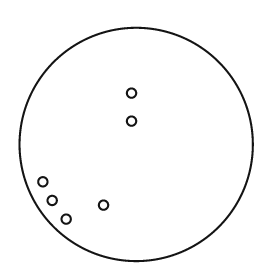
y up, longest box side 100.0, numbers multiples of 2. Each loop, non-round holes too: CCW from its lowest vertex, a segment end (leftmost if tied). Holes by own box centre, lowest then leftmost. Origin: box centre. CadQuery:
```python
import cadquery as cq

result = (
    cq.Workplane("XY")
    .moveTo(0.0, 0.0)
    .circle(50.0)
    .moveTo(-30.0, -32.0)
    .circle(2.0)
    .moveTo(-14.0, -26.0)
    .circle(2.0)
    .moveTo(-36.0, -24.0)
    .circle(2.0)
    .moveTo(-40.0, -16.0)
    .circle(2.0)
    .moveTo(-2.0, 10.0)
    .circle(2.0)
    .moveTo(-2.0, 22.0)
    .circle(2.0)
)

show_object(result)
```